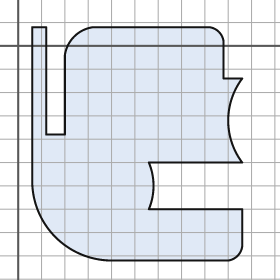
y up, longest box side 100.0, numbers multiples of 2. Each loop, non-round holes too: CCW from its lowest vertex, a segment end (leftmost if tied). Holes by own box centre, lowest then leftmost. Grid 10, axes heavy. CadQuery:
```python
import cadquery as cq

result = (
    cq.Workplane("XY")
    .moveTo(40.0, -92.0)
    .lineTo(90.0, -92.0)
    .threePointArc((94.0, -90.0), (96.0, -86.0))
    .lineTo(96.0, -70.0)
    .lineTo(56.0, -70.0)
    .threePointArc((58.0, -60.0), (56.0, -50.0))
    .lineTo(96.0, -50.0)
    .threePointArc((90.0, -32.0), (96.0, -14.0))
    .lineTo(88.0, -14.0)
    .lineTo(88.0, 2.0)
    .threePointArc((86.0, 6.0), (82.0, 8.0))
    .lineTo(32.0, 8.0)
    .threePointArc((24.0, 4.0), (20.0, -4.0))
    .lineTo(20.0, -38.0)
    .lineTo(12.0, -38.0)
    .lineTo(12.0, 8.0)
    .lineTo(6.0, 8.0)
    .lineTo(6.0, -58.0)
    .threePointArc((16.0, -82.0), (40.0, -92.0))
    .close()
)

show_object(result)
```